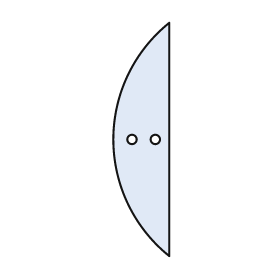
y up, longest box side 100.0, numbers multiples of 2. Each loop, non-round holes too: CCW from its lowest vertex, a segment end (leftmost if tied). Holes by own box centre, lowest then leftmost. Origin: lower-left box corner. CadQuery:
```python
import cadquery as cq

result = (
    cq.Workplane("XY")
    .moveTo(24.0, 0.0)
    .lineTo(24.0, 100.0)
    .threePointArc((0.0, 50.0), (24.0, 0.0))
    .close()
    .moveTo(8.0, 50.0)
    .circle(2.0)
    .moveTo(18.0, 50.0)
    .circle(2.0)
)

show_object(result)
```